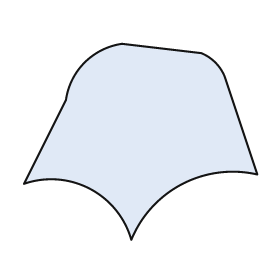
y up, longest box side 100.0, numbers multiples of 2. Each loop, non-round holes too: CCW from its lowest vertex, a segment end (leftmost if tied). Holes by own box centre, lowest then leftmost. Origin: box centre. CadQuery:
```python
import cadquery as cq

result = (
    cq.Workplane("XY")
    .moveTo(-4.0, -42.0)
    .threePointArc((18.0, -18.0), (50.0, -14.0))
    .lineTo(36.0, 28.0)
    .threePointArc((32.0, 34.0), (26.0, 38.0))
    .lineTo(-8.0, 42.0)
    .threePointArc((-24.0, 34.0), (-32.0, 18.0))
    .lineTo(-50.0, -18.0)
    .threePointArc((-22.0, -20.0), (-4.0, -42.0))
    .close()
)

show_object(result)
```